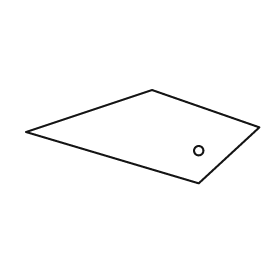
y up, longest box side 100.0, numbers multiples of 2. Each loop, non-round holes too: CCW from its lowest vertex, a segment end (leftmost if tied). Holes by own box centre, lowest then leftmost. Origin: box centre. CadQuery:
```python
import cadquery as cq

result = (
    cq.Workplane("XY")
    .moveTo(24.0, -20.0)
    .lineTo(50.0, 4.0)
    .lineTo(4.0, 20.0)
    .lineTo(-50.0, 2.0)
    .close()
    .moveTo(24.0, -6.0)
    .circle(2.0)
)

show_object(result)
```